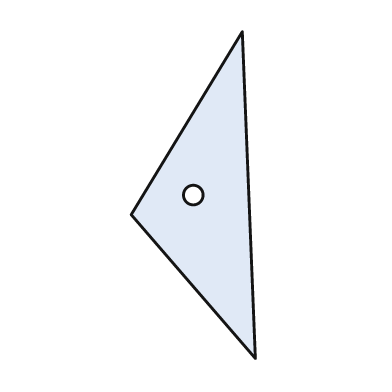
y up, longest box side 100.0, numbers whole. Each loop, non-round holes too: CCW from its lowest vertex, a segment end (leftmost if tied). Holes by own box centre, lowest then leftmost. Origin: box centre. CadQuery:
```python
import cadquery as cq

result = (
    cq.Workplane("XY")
    .moveTo(19.0, -50.0)
    .lineTo(15.0, 50.0)
    .lineTo(-19.0, -6.0)
    .close()
    .moveTo(0.0, 0.0)
    .circle(3.0)
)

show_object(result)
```